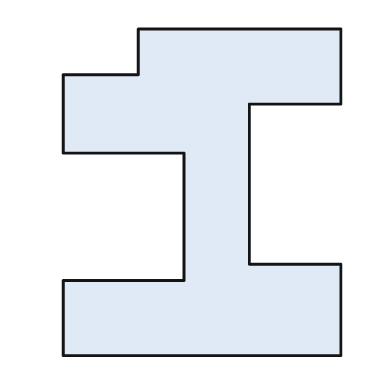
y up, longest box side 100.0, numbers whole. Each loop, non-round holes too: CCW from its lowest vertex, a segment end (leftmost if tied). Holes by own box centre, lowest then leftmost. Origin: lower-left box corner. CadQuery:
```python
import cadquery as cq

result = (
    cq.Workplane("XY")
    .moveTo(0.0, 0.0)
    .lineTo(85.0, 0.0)
    .lineTo(85.0, 28.0)
    .lineTo(57.0, 28.0)
    .lineTo(57.0, 77.0)
    .lineTo(85.0, 77.0)
    .lineTo(85.0, 100.0)
    .lineTo(23.0, 100.0)
    .lineTo(23.0, 86.0)
    .lineTo(0.0, 86.0)
    .lineTo(0.0, 62.0)
    .lineTo(37.0, 62.0)
    .lineTo(37.0, 23.0)
    .lineTo(0.0, 23.0)
    .close()
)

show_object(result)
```